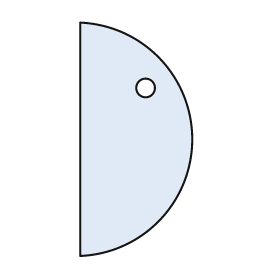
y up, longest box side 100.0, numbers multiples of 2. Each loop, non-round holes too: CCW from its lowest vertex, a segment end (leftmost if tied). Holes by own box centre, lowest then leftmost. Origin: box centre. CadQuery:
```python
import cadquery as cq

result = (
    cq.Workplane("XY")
    .moveTo(-24.0, -50.0)
    .threePointArc((24.0, 0.0), (-24.0, 50.0))
    .close()
    .moveTo(4.0, 22.0)
    .circle(4.0)
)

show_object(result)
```